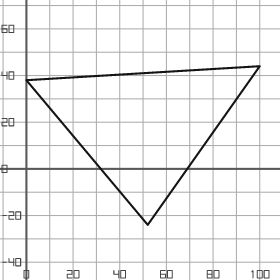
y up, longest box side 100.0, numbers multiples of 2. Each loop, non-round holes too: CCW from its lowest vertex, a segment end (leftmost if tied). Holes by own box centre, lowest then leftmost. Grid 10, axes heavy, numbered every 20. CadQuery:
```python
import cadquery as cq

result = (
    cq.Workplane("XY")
    .moveTo(52.0, -24.0)
    .lineTo(100.0, 44.0)
    .lineTo(0.0, 38.0)
    .close()
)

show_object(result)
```